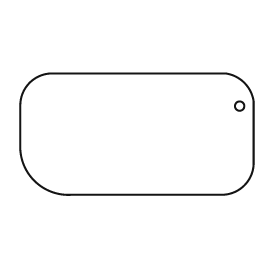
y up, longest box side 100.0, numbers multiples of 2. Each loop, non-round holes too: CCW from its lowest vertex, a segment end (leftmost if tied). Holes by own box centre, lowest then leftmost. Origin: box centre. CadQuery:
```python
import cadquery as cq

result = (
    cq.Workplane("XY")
    .moveTo(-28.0, -26.0)
    .lineTo(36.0, -26.0)
    .threePointArc((46.0, -22.0), (50.0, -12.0))
    .lineTo(50.0, 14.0)
    .threePointArc((46.0, 22.0), (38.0, 26.0))
    .lineTo(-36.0, 26.0)
    .threePointArc((-46.0, 22.0), (-50.0, 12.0))
    .lineTo(-50.0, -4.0)
    .threePointArc((-44.0, -20.0), (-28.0, -26.0))
    .close()
    .moveTo(44.0, 12.0)
    .circle(2.0)
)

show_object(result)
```